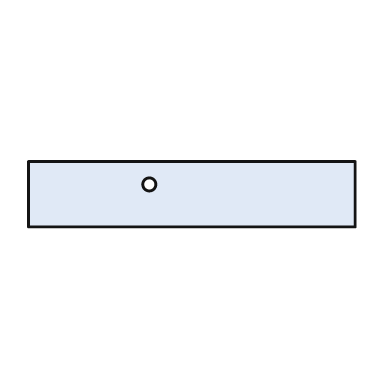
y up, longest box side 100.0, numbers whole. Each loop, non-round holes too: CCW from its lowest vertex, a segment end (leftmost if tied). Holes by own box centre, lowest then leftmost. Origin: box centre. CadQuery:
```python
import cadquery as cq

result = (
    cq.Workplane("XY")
    .moveTo(-50.0, -10.0)
    .lineTo(50.0, -10.0)
    .lineTo(50.0, 10.0)
    .lineTo(-50.0, 10.0)
    .close()
    .moveTo(-13.0, 3.0)
    .circle(2.0)
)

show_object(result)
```